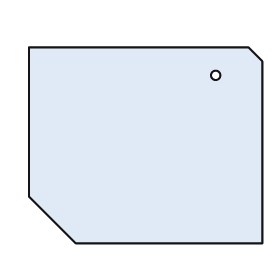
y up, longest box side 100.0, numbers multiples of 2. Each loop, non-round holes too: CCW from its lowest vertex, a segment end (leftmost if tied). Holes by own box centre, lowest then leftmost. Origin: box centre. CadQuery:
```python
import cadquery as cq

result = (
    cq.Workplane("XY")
    .moveTo(-30.0, -42.0)
    .lineTo(50.0, -42.0)
    .lineTo(50.0, 36.0)
    .lineTo(44.0, 42.0)
    .lineTo(-50.0, 42.0)
    .lineTo(-50.0, -22.0)
    .close()
    .moveTo(30.0, 30.0)
    .circle(2.0)
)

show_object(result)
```